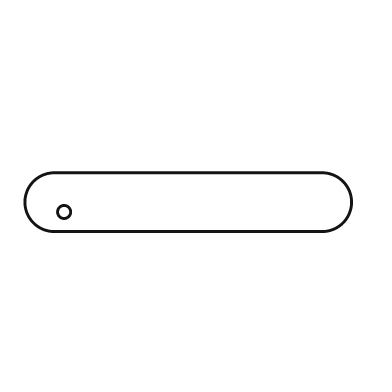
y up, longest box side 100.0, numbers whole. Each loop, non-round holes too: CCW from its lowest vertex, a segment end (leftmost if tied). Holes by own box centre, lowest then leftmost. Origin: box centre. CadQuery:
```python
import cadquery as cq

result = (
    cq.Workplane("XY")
    .moveTo(-41.0, -9.0)
    .lineTo(41.0, -9.0)
    .threePointArc((50.0, 0.0), (41.0, 9.0))
    .lineTo(-41.0, 9.0)
    .threePointArc((-50.0, 0.0), (-41.0, -9.0))
    .close()
    .moveTo(-38.0, -3.0)
    .circle(2.0)
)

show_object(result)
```